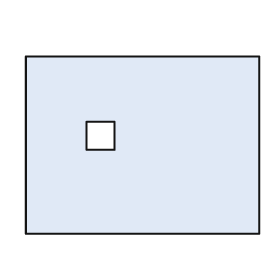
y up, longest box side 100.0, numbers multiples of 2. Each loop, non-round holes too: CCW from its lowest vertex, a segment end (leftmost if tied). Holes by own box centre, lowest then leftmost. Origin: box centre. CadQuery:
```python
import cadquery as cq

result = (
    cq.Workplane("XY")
    .moveTo(-50.0, -38.0)
    .lineTo(50.0, -38.0)
    .lineTo(50.0, 38.0)
    .lineTo(-50.0, 38.0)
    .close()
    .moveTo(-24.0, -2.0)
    .lineTo(-12.0, -2.0)
    .lineTo(-12.0, 10.0)
    .lineTo(-24.0, 10.0)
    .close()
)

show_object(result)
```